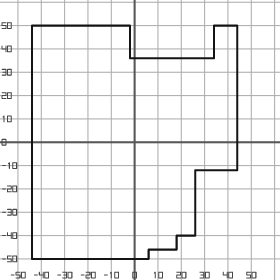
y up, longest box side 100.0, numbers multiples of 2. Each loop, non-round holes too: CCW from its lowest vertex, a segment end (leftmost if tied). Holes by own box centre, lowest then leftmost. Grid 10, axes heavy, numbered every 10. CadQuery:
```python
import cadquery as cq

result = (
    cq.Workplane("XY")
    .moveTo(-44.0, -50.0)
    .lineTo(6.0, -50.0)
    .lineTo(6.0, -46.0)
    .lineTo(18.0, -46.0)
    .lineTo(18.0, -40.0)
    .lineTo(26.0, -40.0)
    .lineTo(26.0, -12.0)
    .lineTo(44.0, -12.0)
    .lineTo(44.0, 50.0)
    .lineTo(34.0, 50.0)
    .lineTo(34.0, 36.0)
    .lineTo(-2.0, 36.0)
    .lineTo(-2.0, 50.0)
    .lineTo(-44.0, 50.0)
    .close()
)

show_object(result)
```